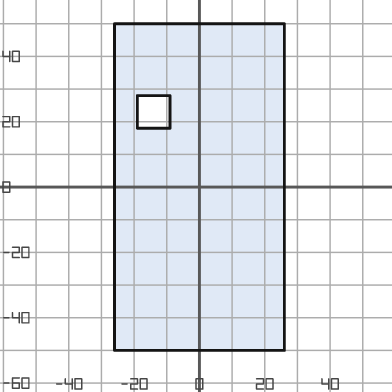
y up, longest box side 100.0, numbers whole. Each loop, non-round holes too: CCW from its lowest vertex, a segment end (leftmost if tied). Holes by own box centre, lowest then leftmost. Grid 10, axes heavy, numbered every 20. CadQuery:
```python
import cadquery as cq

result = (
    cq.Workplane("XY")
    .moveTo(-26.0, -50.0)
    .lineTo(26.0, -50.0)
    .lineTo(26.0, 50.0)
    .lineTo(-26.0, 50.0)
    .close()
    .moveTo(-19.0, 18.0)
    .lineTo(-9.0, 18.0)
    .lineTo(-9.0, 28.0)
    .lineTo(-19.0, 28.0)
    .close()
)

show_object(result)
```